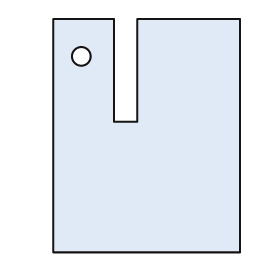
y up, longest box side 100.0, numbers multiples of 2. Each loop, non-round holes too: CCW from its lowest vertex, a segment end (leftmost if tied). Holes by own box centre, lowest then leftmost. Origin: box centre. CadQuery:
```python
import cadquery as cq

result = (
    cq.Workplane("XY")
    .moveTo(-40.0, -50.0)
    .lineTo(40.0, -50.0)
    .lineTo(40.0, 50.0)
    .lineTo(-4.0, 50.0)
    .lineTo(-4.0, 6.0)
    .lineTo(-14.0, 6.0)
    .lineTo(-14.0, 50.0)
    .lineTo(-40.0, 50.0)
    .close()
    .moveTo(-28.0, 34.0)
    .circle(4.0)
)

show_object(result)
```